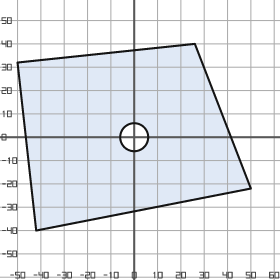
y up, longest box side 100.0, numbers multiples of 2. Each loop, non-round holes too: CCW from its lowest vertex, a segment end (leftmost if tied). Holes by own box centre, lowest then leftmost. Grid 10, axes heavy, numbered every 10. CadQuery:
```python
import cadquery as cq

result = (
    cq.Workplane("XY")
    .moveTo(-42.0, -40.0)
    .lineTo(50.0, -22.0)
    .lineTo(26.0, 40.0)
    .lineTo(-50.0, 32.0)
    .close()
    .moveTo(0.0, 0.0)
    .circle(6.0)
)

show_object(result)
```